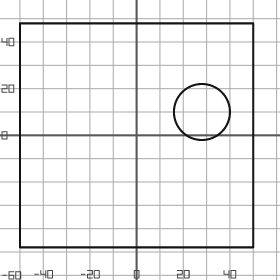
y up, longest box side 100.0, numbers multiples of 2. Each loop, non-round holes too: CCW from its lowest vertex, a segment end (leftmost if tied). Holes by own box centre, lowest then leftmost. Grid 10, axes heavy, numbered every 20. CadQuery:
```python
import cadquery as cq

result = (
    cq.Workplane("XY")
    .moveTo(-50.0, -48.0)
    .lineTo(50.0, -48.0)
    .lineTo(50.0, 48.0)
    .lineTo(-50.0, 48.0)
    .close()
    .moveTo(28.0, 10.0)
    .circle(12.0)
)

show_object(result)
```